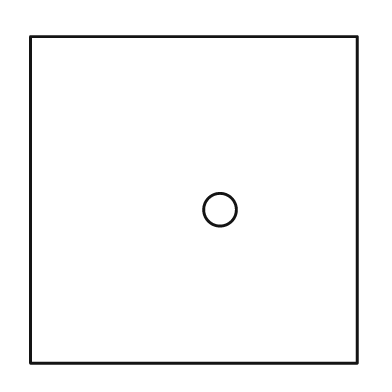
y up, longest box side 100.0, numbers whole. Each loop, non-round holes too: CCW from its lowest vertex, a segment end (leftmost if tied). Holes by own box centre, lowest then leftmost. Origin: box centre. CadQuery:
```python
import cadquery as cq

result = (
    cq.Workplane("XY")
    .moveTo(-50.0, -50.0)
    .lineTo(50.0, -50.0)
    .lineTo(50.0, 50.0)
    .lineTo(-50.0, 50.0)
    .close()
    .moveTo(8.0, -3.0)
    .circle(5.0)
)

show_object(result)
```